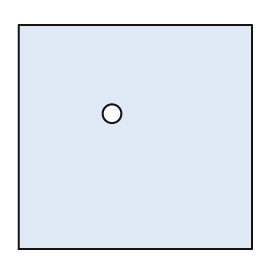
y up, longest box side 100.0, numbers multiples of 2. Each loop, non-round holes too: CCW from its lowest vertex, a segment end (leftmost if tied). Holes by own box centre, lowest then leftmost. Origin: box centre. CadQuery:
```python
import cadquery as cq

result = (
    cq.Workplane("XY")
    .moveTo(-50.0, -48.0)
    .lineTo(50.0, -48.0)
    .lineTo(50.0, 48.0)
    .lineTo(-50.0, 48.0)
    .close()
    .moveTo(-10.0, 10.0)
    .circle(4.0)
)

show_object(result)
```